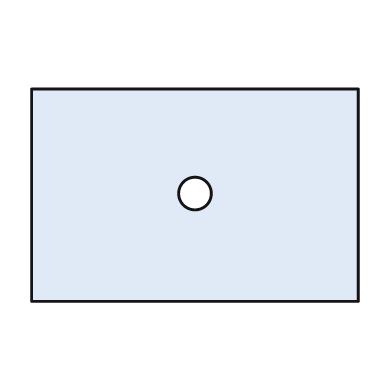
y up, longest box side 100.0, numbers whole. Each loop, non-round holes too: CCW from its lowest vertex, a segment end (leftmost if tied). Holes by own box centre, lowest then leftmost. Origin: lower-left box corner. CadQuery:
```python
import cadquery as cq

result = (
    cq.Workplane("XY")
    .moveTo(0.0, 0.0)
    .lineTo(100.0, 0.0)
    .lineTo(100.0, 65.0)
    .lineTo(0.0, 65.0)
    .close()
    .moveTo(50.0, 33.0)
    .circle(5.0)
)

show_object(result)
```